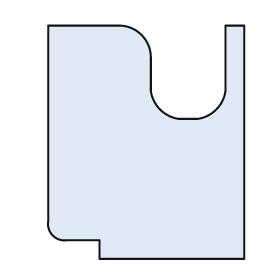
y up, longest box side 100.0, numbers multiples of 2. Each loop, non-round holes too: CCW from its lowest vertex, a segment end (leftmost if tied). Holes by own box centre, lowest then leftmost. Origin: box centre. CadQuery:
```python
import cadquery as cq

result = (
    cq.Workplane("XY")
    .moveTo(-20.0, -50.0)
    .lineTo(42.0, -50.0)
    .lineTo(42.0, 50.0)
    .lineTo(34.0, 50.0)
    .lineTo(34.0, 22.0)
    .threePointArc((30.0, 14.0), (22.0, 10.0))
    .lineTo(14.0, 10.0)
    .threePointArc((6.0, 14.0), (2.0, 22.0))
    .lineTo(2.0, 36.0)
    .threePointArc((-2.0, 46.0), (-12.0, 50.0))
    .lineTo(-42.0, 50.0)
    .lineTo(-42.0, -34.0)
    .threePointArc((-40.0, -40.0), (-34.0, -42.0))
    .lineTo(-20.0, -42.0)
    .close()
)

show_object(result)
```